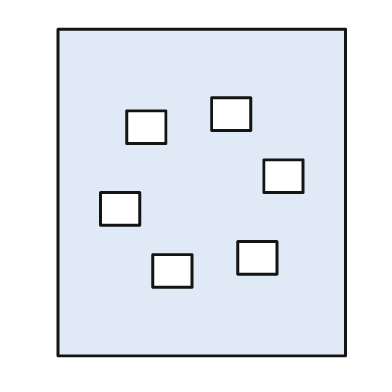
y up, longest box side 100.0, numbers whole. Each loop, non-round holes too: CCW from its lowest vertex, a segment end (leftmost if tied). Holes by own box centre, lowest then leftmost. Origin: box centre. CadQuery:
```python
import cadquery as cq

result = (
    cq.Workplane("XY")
    .moveTo(-44.0, -50.0)
    .lineTo(44.0, -50.0)
    .lineTo(44.0, 50.0)
    .lineTo(-44.0, 50.0)
    .close()
    .moveTo(-15.0, -29.0)
    .lineTo(-3.0, -29.0)
    .lineTo(-3.0, -19.0)
    .lineTo(-15.0, -19.0)
    .close()
    .moveTo(11.0, -25.0)
    .lineTo(23.0, -25.0)
    .lineTo(23.0, -15.0)
    .lineTo(11.0, -15.0)
    .close()
    .moveTo(-31.0, -10.0)
    .lineTo(-19.0, -10.0)
    .lineTo(-19.0, 0.0)
    .lineTo(-31.0, 0.0)
    .close()
    .moveTo(19.0, 0.0)
    .lineTo(31.0, 0.0)
    .lineTo(31.0, 10.0)
    .lineTo(19.0, 10.0)
    .close()
    .moveTo(-23.0, 15.0)
    .lineTo(-11.0, 15.0)
    .lineTo(-11.0, 25.0)
    .lineTo(-23.0, 25.0)
    .close()
    .moveTo(3.0, 19.0)
    .lineTo(15.0, 19.0)
    .lineTo(15.0, 29.0)
    .lineTo(3.0, 29.0)
    .close()
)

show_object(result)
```